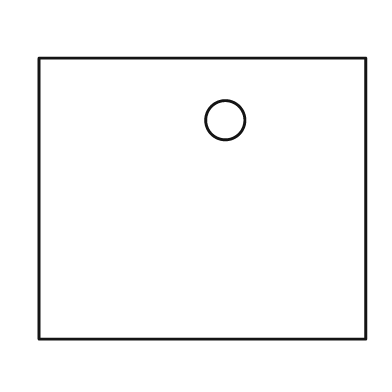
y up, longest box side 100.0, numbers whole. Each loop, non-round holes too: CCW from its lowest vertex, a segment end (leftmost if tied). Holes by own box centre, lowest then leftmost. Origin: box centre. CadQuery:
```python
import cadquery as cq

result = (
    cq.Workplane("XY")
    .moveTo(-50.0, -43.0)
    .lineTo(50.0, -43.0)
    .lineTo(50.0, 43.0)
    .lineTo(-50.0, 43.0)
    .close()
    .moveTo(7.0, 24.0)
    .circle(6.0)
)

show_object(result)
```